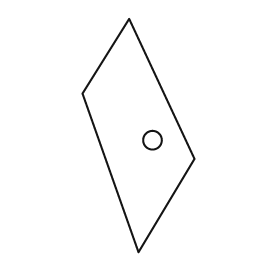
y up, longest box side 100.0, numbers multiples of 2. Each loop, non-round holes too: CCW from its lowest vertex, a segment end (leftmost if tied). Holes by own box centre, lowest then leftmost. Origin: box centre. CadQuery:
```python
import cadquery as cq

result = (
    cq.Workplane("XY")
    .moveTo(0.0, -50.0)
    .lineTo(24.0, -10.0)
    .lineTo(-4.0, 50.0)
    .lineTo(-24.0, 18.0)
    .close()
    .moveTo(6.0, -2.0)
    .circle(4.0)
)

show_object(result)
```